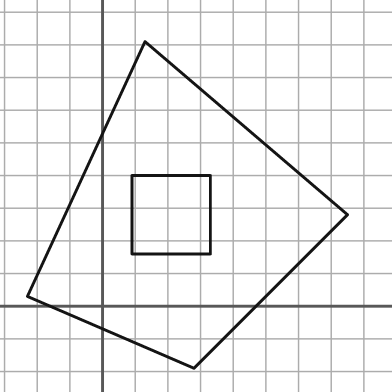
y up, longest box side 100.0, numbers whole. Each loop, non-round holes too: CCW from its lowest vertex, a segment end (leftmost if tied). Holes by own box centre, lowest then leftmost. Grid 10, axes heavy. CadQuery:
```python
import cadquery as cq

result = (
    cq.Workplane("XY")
    .moveTo(28.0, -19.0)
    .lineTo(75.0, 28.0)
    .lineTo(13.0, 81.0)
    .lineTo(-23.0, 3.0)
    .close()
    .moveTo(9.0, 16.0)
    .lineTo(33.0, 16.0)
    .lineTo(33.0, 40.0)
    .lineTo(9.0, 40.0)
    .close()
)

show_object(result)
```